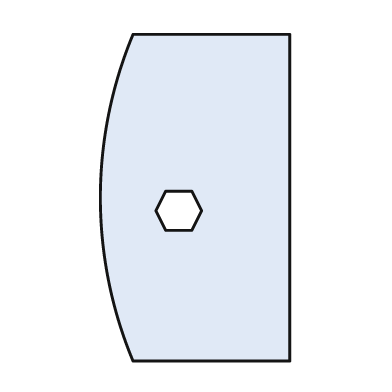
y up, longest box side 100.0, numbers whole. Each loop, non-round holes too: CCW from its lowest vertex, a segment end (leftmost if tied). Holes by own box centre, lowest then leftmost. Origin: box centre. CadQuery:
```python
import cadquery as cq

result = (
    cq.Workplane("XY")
    .moveTo(-19.0, -50.0)
    .lineTo(29.0, -50.0)
    .lineTo(29.0, 50.0)
    .lineTo(-19.0, 50.0)
    .threePointArc((-29.0, 0.0), (-19.0, -50.0))
    .close()
    .moveTo(-9.0, -10.0)
    .lineTo(-1.0, -10.0)
    .lineTo(2.0, -4.0)
    .lineTo(-1.0, 2.0)
    .lineTo(-9.0, 2.0)
    .lineTo(-12.0, -4.0)
    .close()
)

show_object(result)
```